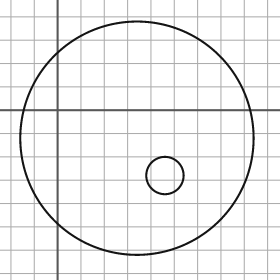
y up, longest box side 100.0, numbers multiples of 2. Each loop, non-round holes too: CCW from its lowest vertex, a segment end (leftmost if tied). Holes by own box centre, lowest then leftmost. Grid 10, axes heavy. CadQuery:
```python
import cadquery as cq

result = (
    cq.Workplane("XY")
    .moveTo(34.0, -12.0)
    .circle(50.0)
    .moveTo(46.0, -28.0)
    .circle(8.0)
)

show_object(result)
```